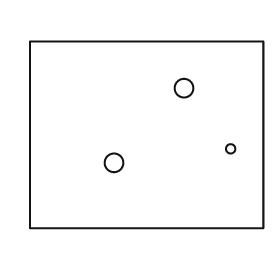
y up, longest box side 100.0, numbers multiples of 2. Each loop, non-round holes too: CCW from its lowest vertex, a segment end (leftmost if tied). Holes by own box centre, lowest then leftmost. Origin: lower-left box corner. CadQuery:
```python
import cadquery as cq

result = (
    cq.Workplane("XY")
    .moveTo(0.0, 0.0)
    .lineTo(100.0, 0.0)
    .lineTo(100.0, 80.0)
    .lineTo(0.0, 80.0)
    .close()
    .moveTo(36.0, 28.0)
    .circle(4.0)
    .moveTo(86.0, 34.0)
    .circle(2.0)
    .moveTo(66.0, 60.0)
    .circle(4.0)
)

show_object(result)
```